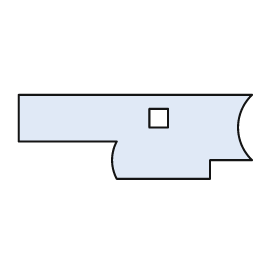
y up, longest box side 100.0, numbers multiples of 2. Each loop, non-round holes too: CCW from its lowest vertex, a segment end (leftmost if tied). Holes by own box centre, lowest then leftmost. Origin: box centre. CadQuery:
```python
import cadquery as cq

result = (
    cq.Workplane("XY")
    .moveTo(-8.0, -18.0)
    .lineTo(32.0, -18.0)
    .lineTo(32.0, -10.0)
    .lineTo(50.0, -10.0)
    .threePointArc((44.0, 4.0), (50.0, 18.0))
    .lineTo(-50.0, 18.0)
    .lineTo(-50.0, -2.0)
    .lineTo(-8.0, -2.0)
    .threePointArc((-10.0, -10.0), (-8.0, -18.0))
    .close()
    .moveTo(6.0, 4.0)
    .lineTo(14.0, 4.0)
    .lineTo(14.0, 12.0)
    .lineTo(6.0, 12.0)
    .close()
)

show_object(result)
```